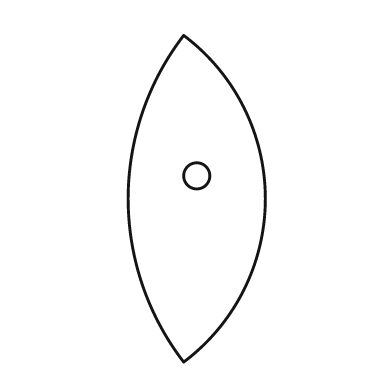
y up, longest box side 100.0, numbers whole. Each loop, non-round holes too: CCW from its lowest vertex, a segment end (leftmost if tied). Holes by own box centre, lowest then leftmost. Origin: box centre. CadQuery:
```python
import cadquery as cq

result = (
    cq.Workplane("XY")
    .moveTo(-4.0, -50.0)
    .threePointArc((21.0, 0.0), (-4.0, 50.0))
    .threePointArc((-21.0, 0.0), (-4.0, -50.0))
    .close()
    .moveTo(0.0, 7.0)
    .circle(4.0)
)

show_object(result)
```